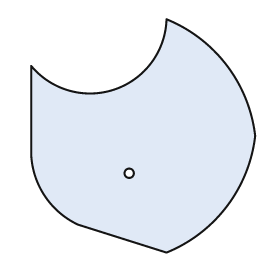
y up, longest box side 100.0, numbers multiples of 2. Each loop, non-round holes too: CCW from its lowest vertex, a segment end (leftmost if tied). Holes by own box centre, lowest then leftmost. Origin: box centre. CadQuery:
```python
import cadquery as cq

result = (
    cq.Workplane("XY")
    .moveTo(10.0, -50.0)
    .threePointArc((36.0, -30.0), (48.0, 0.0))
    .threePointArc((36.0, 30.0), (10.0, 50.0))
    .threePointArc((-12.0, 20.0), (-48.0, 30.0))
    .lineTo(-48.0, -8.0)
    .threePointArc((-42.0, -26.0), (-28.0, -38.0))
    .close()
    .moveTo(-6.0, -16.0)
    .circle(2.0)
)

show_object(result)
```